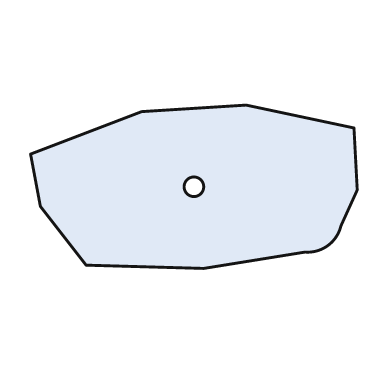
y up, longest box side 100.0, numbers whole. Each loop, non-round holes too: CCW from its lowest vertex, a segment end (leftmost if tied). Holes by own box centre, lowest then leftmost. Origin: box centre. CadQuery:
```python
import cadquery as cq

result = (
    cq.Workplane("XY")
    .moveTo(3.0, -25.0)
    .lineTo(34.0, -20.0)
    .threePointArc((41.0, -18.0), (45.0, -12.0))
    .lineTo(50.0, -1.0)
    .lineTo(49.0, 18.0)
    .lineTo(16.0, 25.0)
    .lineTo(-16.0, 23.0)
    .lineTo(-50.0, 10.0)
    .lineTo(-47.0, -6.0)
    .lineTo(-33.0, -24.0)
    .close()
    .moveTo(0.0, 0.0)
    .circle(3.0)
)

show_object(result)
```